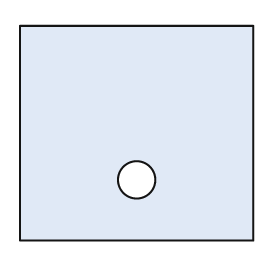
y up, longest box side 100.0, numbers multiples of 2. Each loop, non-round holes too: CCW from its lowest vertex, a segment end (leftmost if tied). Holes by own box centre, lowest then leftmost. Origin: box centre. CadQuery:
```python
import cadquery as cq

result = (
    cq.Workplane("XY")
    .moveTo(-50.0, -46.0)
    .lineTo(50.0, -46.0)
    .lineTo(50.0, 46.0)
    .lineTo(-50.0, 46.0)
    .close()
    .moveTo(0.0, -20.0)
    .circle(8.0)
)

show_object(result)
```